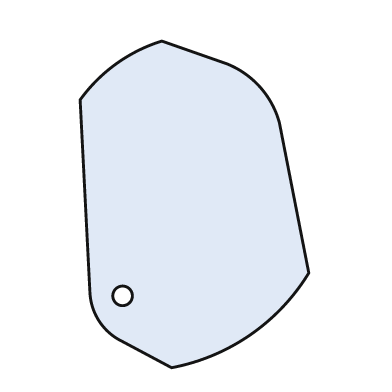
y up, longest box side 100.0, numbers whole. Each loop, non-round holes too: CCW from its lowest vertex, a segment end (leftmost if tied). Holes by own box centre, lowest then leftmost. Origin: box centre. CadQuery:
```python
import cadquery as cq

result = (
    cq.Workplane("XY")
    .moveTo(-7.0, -50.0)
    .threePointArc((17.0, -40.0), (35.0, -21.0))
    .lineTo(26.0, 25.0)
    .threePointArc((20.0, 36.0), (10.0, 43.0))
    .lineTo(-10.0, 50.0)
    .threePointArc((-24.0, 43.0), (-35.0, 32.0))
    .lineTo(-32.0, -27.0)
    .threePointArc((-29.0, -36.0), (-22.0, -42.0))
    .close()
    .moveTo(-22.0, -28.0)
    .circle(3.0)
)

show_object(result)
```